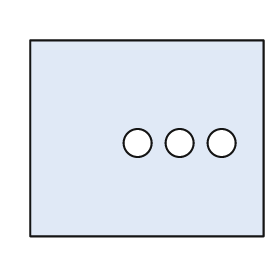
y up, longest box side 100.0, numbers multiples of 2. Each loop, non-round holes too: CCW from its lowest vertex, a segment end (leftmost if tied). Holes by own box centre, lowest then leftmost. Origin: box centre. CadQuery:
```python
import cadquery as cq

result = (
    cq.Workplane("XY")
    .moveTo(-50.0, -42.0)
    .lineTo(50.0, -42.0)
    .lineTo(50.0, 42.0)
    .lineTo(-50.0, 42.0)
    .close()
    .moveTo(-4.0, -2.0)
    .circle(6.0)
    .moveTo(14.0, -2.0)
    .circle(6.0)
    .moveTo(32.0, -2.0)
    .circle(6.0)
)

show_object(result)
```